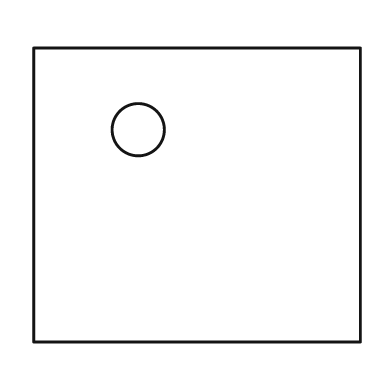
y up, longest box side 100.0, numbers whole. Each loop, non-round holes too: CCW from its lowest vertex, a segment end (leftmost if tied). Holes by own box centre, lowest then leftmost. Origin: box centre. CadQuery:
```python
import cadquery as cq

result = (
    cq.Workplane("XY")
    .moveTo(-50.0, -45.0)
    .lineTo(50.0, -45.0)
    .lineTo(50.0, 45.0)
    .lineTo(-50.0, 45.0)
    .close()
    .moveTo(-18.0, 20.0)
    .circle(8.0)
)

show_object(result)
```